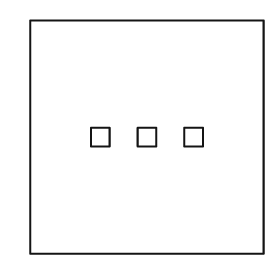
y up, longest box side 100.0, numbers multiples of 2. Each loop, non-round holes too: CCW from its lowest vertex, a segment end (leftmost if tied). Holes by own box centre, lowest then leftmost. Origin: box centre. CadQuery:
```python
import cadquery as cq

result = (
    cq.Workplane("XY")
    .moveTo(-50.0, -50.0)
    .lineTo(50.0, -50.0)
    .lineTo(50.0, 50.0)
    .lineTo(-50.0, 50.0)
    .close()
    .moveTo(-24.0, -4.0)
    .lineTo(-16.0, -4.0)
    .lineTo(-16.0, 4.0)
    .lineTo(-24.0, 4.0)
    .close()
    .moveTo(-4.0, -4.0)
    .lineTo(4.0, -4.0)
    .lineTo(4.0, 4.0)
    .lineTo(-4.0, 4.0)
    .close()
    .moveTo(16.0, -4.0)
    .lineTo(24.0, -4.0)
    .lineTo(24.0, 4.0)
    .lineTo(16.0, 4.0)
    .close()
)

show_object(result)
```